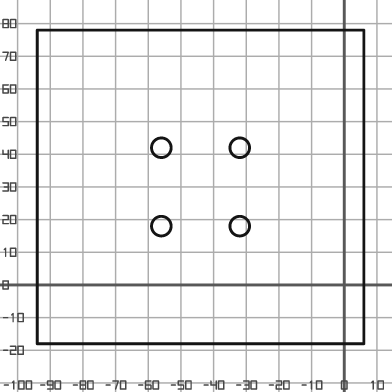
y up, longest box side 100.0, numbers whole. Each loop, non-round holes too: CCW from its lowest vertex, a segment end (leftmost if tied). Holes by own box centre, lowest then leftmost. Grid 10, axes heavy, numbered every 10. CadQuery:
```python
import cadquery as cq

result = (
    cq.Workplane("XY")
    .moveTo(-94.0, -18.0)
    .lineTo(6.0, -18.0)
    .lineTo(6.0, 78.0)
    .lineTo(-94.0, 78.0)
    .close()
    .moveTo(-56.0, 18.0)
    .circle(3.0)
    .moveTo(-32.0, 18.0)
    .circle(3.0)
    .moveTo(-56.0, 42.0)
    .circle(3.0)
    .moveTo(-32.0, 42.0)
    .circle(3.0)
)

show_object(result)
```